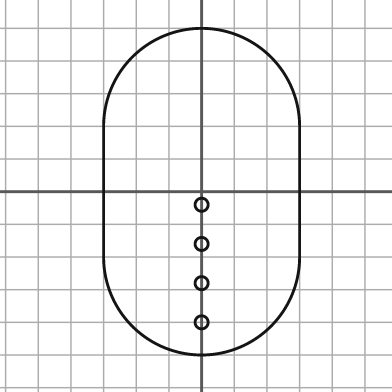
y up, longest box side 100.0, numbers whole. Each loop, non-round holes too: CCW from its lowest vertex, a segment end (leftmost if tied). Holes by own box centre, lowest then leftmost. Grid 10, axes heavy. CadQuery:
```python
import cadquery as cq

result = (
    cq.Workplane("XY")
    .moveTo(-30.0, -20.0)
    .threePointArc((0.0, -50.0), (30.0, -20.0))
    .lineTo(30.0, 20.0)
    .threePointArc((0.0, 50.0), (-30.0, 20.0))
    .close()
    .moveTo(0.0, -40.0)
    .circle(2.0)
    .moveTo(0.0, -28.0)
    .circle(2.0)
    .moveTo(0.0, -16.0)
    .circle(2.0)
    .moveTo(0.0, -4.0)
    .circle(2.0)
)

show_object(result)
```